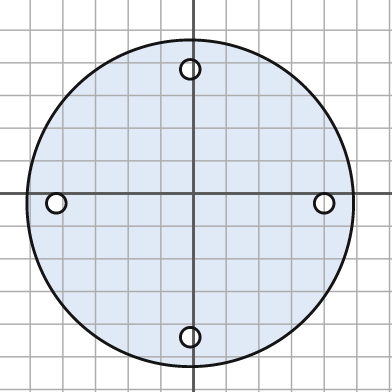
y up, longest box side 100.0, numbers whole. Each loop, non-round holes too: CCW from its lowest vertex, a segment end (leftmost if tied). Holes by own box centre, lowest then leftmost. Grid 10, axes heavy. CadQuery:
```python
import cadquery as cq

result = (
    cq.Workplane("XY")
    .moveTo(-1.0, -3.0)
    .circle(50.0)
    .moveTo(-1.0, -44.0)
    .circle(3.0)
    .moveTo(-42.0, -3.0)
    .circle(3.0)
    .moveTo(40.0, -3.0)
    .circle(3.0)
    .moveTo(-1.0, 38.0)
    .circle(3.0)
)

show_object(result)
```